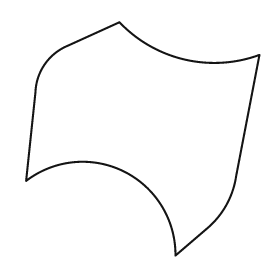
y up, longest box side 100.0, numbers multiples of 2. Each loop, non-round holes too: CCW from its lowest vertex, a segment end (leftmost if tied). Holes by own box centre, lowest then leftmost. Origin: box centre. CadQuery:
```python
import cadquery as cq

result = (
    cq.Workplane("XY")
    .moveTo(14.0, -50.0)
    .lineTo(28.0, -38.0)
    .threePointArc((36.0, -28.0), (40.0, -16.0))
    .lineTo(50.0, 36.0)
    .threePointArc((18.0, 34.0), (-10.0, 50.0))
    .lineTo(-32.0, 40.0)
    .threePointArc((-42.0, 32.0), (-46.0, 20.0))
    .lineTo(-50.0, -18.0)
    .threePointArc((-8.0, -14.0), (14.0, -50.0))
    .close()
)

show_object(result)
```